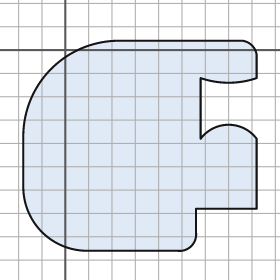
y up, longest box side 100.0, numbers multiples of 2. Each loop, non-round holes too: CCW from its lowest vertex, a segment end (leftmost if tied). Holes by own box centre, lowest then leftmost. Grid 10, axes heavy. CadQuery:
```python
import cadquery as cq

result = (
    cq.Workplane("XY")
    .moveTo(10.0, -86.0)
    .lineTo(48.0, -86.0)
    .threePointArc((54.0, -84.0), (56.0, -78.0))
    .lineTo(56.0, -68.0)
    .lineTo(82.0, -68.0)
    .lineTo(82.0, -38.0)
    .threePointArc((70.0, -32.0), (58.0, -38.0))
    .lineTo(58.0, -12.0)
    .threePointArc((70.0, -14.0), (82.0, -12.0))
    .lineTo(82.0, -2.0)
    .threePointArc((80.0, 2.0), (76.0, 4.0))
    .lineTo(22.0, 4.0)
    .threePointArc((-6.0, -8.0), (-18.0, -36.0))
    .lineTo(-18.0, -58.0)
    .threePointArc((-10.0, -78.0), (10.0, -86.0))
    .close()
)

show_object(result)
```